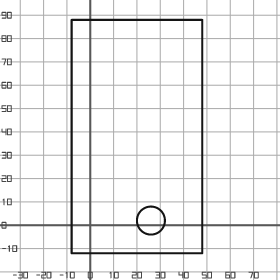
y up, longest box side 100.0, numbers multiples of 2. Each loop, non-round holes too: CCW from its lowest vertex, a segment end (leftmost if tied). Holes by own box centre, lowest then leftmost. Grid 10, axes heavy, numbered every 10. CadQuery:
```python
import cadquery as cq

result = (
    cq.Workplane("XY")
    .moveTo(-8.0, -12.0)
    .lineTo(48.0, -12.0)
    .lineTo(48.0, 88.0)
    .lineTo(-8.0, 88.0)
    .close()
    .moveTo(26.0, 2.0)
    .circle(6.0)
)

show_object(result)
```